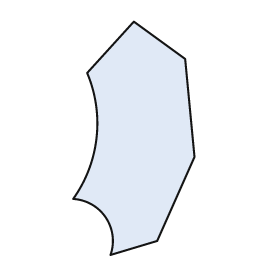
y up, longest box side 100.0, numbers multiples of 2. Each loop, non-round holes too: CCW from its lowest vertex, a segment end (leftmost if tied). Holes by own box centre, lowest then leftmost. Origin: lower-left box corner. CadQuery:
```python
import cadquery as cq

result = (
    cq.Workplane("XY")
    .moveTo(16.0, 0.0)
    .lineTo(36.0, 6.0)
    .lineTo(52.0, 42.0)
    .lineTo(48.0, 84.0)
    .lineTo(26.0, 100.0)
    .lineTo(6.0, 78.0)
    .threePointArc((10.0, 50.0), (0.0, 24.0))
    .threePointArc((14.0, 16.0), (16.0, 0.0))
    .close()
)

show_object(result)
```